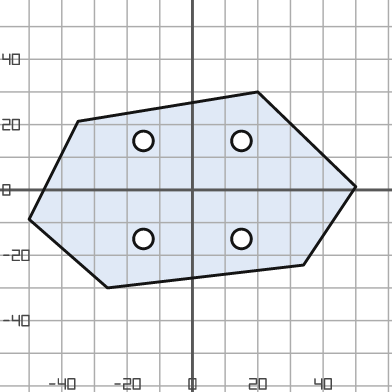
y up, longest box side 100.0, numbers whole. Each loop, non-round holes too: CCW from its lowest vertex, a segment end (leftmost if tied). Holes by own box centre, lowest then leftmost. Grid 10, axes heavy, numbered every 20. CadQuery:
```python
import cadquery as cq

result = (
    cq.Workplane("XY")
    .moveTo(-26.0, -30.0)
    .lineTo(34.0, -23.0)
    .lineTo(50.0, 1.0)
    .lineTo(20.0, 30.0)
    .lineTo(-35.0, 21.0)
    .lineTo(-50.0, -9.0)
    .close()
    .moveTo(-15.0, -15.0)
    .circle(3.0)
    .moveTo(15.0, -15.0)
    .circle(3.0)
    .moveTo(-15.0, 15.0)
    .circle(3.0)
    .moveTo(15.0, 15.0)
    .circle(3.0)
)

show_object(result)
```